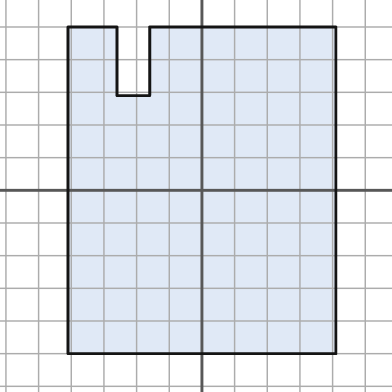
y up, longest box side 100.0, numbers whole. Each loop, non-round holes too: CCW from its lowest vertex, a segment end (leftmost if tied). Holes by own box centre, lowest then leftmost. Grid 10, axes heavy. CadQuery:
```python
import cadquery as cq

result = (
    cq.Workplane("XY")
    .moveTo(-41.0, -50.0)
    .lineTo(41.0, -50.0)
    .lineTo(41.0, 50.0)
    .lineTo(-16.0, 50.0)
    .lineTo(-16.0, 29.0)
    .lineTo(-26.0, 29.0)
    .lineTo(-26.0, 50.0)
    .lineTo(-41.0, 50.0)
    .close()
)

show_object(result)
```